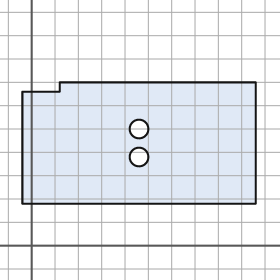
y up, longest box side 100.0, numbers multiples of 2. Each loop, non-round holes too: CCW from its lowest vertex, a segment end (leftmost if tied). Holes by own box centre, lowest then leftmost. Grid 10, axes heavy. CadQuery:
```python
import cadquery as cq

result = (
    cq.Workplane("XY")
    .moveTo(-4.0, 18.0)
    .lineTo(96.0, 18.0)
    .lineTo(96.0, 70.0)
    .lineTo(12.0, 70.0)
    .lineTo(12.0, 66.0)
    .lineTo(-4.0, 66.0)
    .close()
    .moveTo(46.0, 38.0)
    .circle(4.0)
    .moveTo(46.0, 50.0)
    .circle(4.0)
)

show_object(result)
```